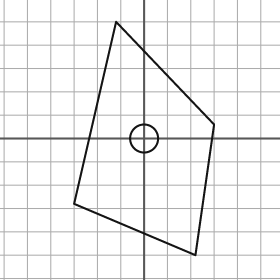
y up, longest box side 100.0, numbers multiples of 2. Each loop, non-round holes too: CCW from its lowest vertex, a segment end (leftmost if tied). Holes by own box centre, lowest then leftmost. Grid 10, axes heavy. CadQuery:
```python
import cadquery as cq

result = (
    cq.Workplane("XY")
    .moveTo(22.0, -50.0)
    .lineTo(30.0, 6.0)
    .lineTo(-12.0, 50.0)
    .lineTo(-30.0, -28.0)
    .close()
    .moveTo(0.0, 0.0)
    .circle(6.0)
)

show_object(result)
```